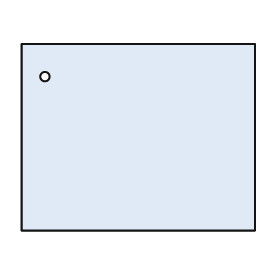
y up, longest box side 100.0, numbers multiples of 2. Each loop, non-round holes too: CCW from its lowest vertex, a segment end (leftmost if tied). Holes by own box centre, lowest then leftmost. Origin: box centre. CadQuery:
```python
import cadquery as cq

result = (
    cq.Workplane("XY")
    .moveTo(-50.0, -40.0)
    .lineTo(50.0, -40.0)
    .lineTo(50.0, 40.0)
    .lineTo(-50.0, 40.0)
    .close()
    .moveTo(-40.0, 26.0)
    .circle(2.0)
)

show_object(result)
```